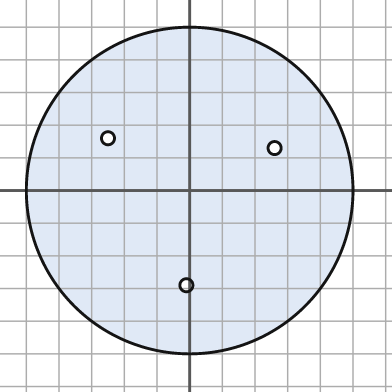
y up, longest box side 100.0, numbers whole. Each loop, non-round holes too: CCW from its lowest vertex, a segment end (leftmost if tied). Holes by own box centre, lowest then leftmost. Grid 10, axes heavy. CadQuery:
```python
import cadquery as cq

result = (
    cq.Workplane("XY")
    .moveTo(0.0, 0.0)
    .circle(50.0)
    .moveTo(-1.0, -29.0)
    .circle(2.0)
    .moveTo(26.0, 13.0)
    .circle(2.0)
    .moveTo(-25.0, 16.0)
    .circle(2.0)
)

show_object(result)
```